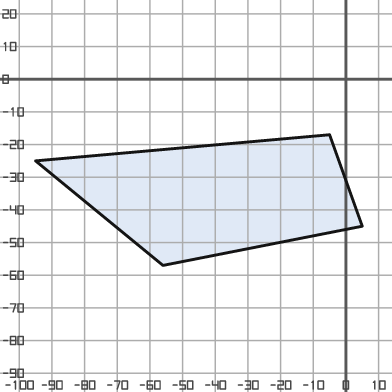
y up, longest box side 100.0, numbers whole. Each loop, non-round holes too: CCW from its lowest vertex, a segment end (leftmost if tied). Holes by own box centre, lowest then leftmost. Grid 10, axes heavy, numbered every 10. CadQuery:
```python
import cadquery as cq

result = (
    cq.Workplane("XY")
    .moveTo(-56.0, -57.0)
    .lineTo(5.0, -45.0)
    .lineTo(-5.0, -17.0)
    .lineTo(-95.0, -25.0)
    .close()
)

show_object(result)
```